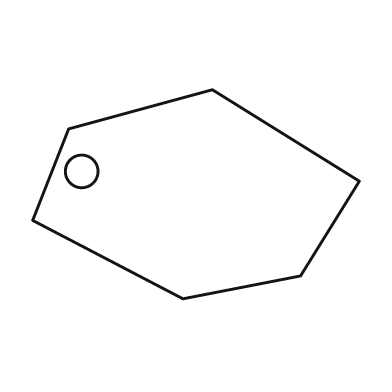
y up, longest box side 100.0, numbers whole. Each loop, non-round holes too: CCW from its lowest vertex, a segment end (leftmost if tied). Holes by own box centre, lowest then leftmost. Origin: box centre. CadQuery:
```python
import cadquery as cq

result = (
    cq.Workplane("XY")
    .moveTo(-4.0, -32.0)
    .lineTo(32.0, -25.0)
    .lineTo(50.0, 4.0)
    .lineTo(5.0, 32.0)
    .lineTo(-39.0, 20.0)
    .lineTo(-50.0, -8.0)
    .close()
    .moveTo(-35.0, 7.0)
    .circle(5.0)
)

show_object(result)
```